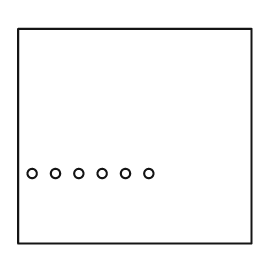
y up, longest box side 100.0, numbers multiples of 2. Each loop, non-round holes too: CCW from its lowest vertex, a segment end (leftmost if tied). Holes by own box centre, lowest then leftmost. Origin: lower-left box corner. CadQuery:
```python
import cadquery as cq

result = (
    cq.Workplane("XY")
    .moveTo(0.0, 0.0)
    .lineTo(100.0, 0.0)
    .lineTo(100.0, 92.0)
    .lineTo(0.0, 92.0)
    .close()
    .moveTo(6.0, 30.0)
    .circle(2.0)
    .moveTo(16.0, 30.0)
    .circle(2.0)
    .moveTo(26.0, 30.0)
    .circle(2.0)
    .moveTo(36.0, 30.0)
    .circle(2.0)
    .moveTo(46.0, 30.0)
    .circle(2.0)
    .moveTo(56.0, 30.0)
    .circle(2.0)
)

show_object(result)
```